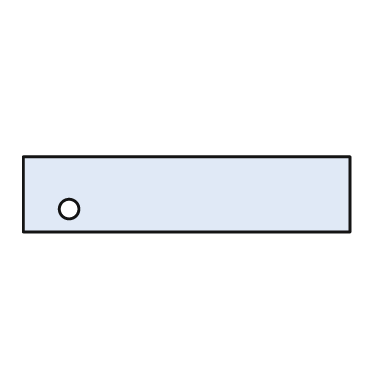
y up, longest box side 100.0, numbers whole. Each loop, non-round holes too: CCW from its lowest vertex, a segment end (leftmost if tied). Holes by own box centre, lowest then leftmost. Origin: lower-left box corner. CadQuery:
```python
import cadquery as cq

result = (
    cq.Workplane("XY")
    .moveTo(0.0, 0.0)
    .lineTo(100.0, 0.0)
    .lineTo(100.0, 23.0)
    .lineTo(0.0, 23.0)
    .close()
    .moveTo(14.0, 7.0)
    .circle(3.0)
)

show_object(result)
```